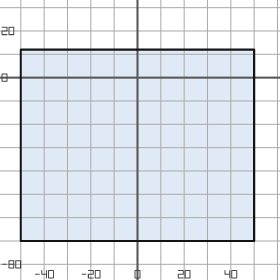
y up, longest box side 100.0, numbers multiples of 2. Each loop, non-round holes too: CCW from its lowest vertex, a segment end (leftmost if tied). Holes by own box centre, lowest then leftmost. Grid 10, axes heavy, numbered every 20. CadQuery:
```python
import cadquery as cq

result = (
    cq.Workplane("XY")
    .moveTo(-50.0, -70.0)
    .lineTo(50.0, -70.0)
    .lineTo(50.0, 12.0)
    .lineTo(-50.0, 12.0)
    .close()
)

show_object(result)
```